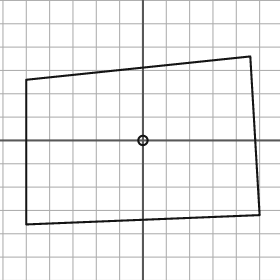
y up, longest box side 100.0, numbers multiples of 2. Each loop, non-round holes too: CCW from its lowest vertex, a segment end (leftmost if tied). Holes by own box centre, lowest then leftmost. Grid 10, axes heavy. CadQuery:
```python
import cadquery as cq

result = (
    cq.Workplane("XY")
    .moveTo(-50.0, -36.0)
    .lineTo(50.0, -32.0)
    .lineTo(46.0, 36.0)
    .lineTo(-50.0, 26.0)
    .close()
    .moveTo(0.0, 0.0)
    .circle(2.0)
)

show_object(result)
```